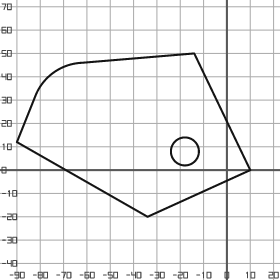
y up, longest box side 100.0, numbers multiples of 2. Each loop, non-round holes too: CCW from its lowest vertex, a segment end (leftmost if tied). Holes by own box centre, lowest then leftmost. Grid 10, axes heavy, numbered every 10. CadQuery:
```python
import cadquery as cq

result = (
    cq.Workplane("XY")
    .moveTo(-34.0, -20.0)
    .lineTo(10.0, 0.0)
    .lineTo(-14.0, 50.0)
    .lineTo(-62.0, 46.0)
    .threePointArc((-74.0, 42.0), (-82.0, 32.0))
    .lineTo(-90.0, 12.0)
    .close()
    .moveTo(-18.0, 8.0)
    .circle(6.0)
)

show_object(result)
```